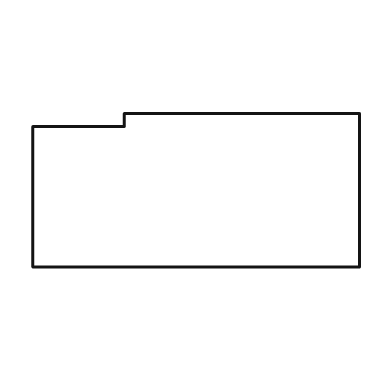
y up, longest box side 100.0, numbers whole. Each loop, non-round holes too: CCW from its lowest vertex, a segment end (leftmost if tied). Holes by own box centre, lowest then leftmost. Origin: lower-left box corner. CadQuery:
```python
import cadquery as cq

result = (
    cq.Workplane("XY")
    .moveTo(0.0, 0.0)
    .lineTo(100.0, 0.0)
    .lineTo(100.0, 47.0)
    .lineTo(28.0, 47.0)
    .lineTo(28.0, 43.0)
    .lineTo(0.0, 43.0)
    .close()
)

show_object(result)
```